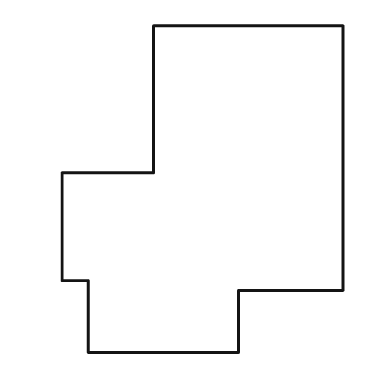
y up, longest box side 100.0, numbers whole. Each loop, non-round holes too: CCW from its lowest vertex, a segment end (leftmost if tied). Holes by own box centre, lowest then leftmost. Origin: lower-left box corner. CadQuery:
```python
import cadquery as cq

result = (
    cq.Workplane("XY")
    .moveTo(8.0, 0.0)
    .lineTo(54.0, 0.0)
    .lineTo(54.0, 19.0)
    .lineTo(86.0, 19.0)
    .lineTo(86.0, 100.0)
    .lineTo(28.0, 100.0)
    .lineTo(28.0, 55.0)
    .lineTo(0.0, 55.0)
    .lineTo(0.0, 22.0)
    .lineTo(8.0, 22.0)
    .close()
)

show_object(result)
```